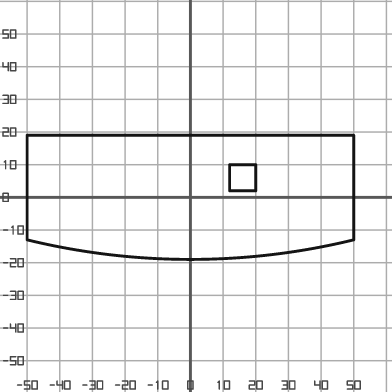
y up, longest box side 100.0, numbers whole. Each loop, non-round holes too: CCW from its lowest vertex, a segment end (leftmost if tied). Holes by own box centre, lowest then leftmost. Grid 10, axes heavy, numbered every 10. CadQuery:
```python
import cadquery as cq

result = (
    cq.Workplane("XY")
    .moveTo(-50.0, -13.0)
    .threePointArc((0.0, -19.0), (50.0, -13.0))
    .lineTo(50.0, 19.0)
    .lineTo(-50.0, 19.0)
    .close()
    .moveTo(12.0, 2.0)
    .lineTo(20.0, 2.0)
    .lineTo(20.0, 10.0)
    .lineTo(12.0, 10.0)
    .close()
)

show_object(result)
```